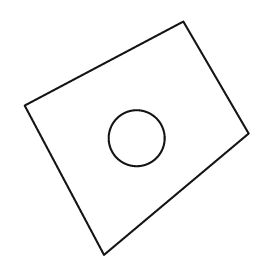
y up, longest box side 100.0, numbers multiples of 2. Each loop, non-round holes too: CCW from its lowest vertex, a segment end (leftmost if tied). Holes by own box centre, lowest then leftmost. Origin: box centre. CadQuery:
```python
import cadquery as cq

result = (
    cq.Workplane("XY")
    .moveTo(-14.0, -50.0)
    .lineTo(48.0, 2.0)
    .lineTo(20.0, 50.0)
    .lineTo(-48.0, 14.0)
    .close()
    .moveTo(0.0, 0.0)
    .circle(12.0)
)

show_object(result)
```